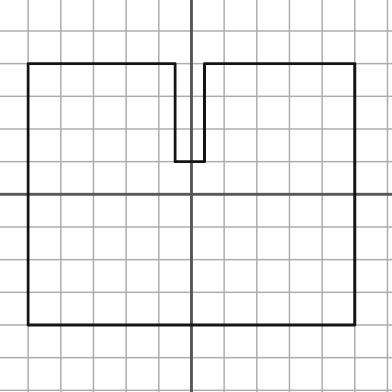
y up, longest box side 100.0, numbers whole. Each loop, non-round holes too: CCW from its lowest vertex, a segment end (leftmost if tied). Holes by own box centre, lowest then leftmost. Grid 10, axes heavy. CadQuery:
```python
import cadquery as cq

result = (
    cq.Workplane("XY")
    .moveTo(-50.0, -40.0)
    .lineTo(50.0, -40.0)
    .lineTo(50.0, 40.0)
    .lineTo(4.0, 40.0)
    .lineTo(4.0, 10.0)
    .lineTo(-5.0, 10.0)
    .lineTo(-5.0, 40.0)
    .lineTo(-50.0, 40.0)
    .close()
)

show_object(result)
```